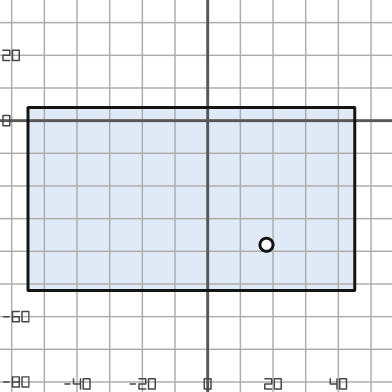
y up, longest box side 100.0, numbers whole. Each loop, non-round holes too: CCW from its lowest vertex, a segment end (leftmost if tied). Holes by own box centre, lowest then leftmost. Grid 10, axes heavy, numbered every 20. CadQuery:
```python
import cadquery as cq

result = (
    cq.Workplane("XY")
    .moveTo(-55.0, -52.0)
    .lineTo(45.0, -52.0)
    .lineTo(45.0, 4.0)
    .lineTo(-55.0, 4.0)
    .close()
    .moveTo(18.0, -38.0)
    .circle(2.0)
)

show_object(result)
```